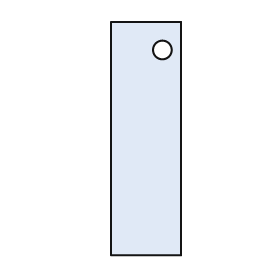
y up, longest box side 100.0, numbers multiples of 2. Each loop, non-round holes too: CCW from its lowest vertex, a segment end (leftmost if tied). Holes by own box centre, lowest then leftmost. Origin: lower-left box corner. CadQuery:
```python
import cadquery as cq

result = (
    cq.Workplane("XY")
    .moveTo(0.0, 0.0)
    .lineTo(30.0, 0.0)
    .lineTo(30.0, 100.0)
    .lineTo(0.0, 100.0)
    .close()
    .moveTo(22.0, 88.0)
    .circle(4.0)
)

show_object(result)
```